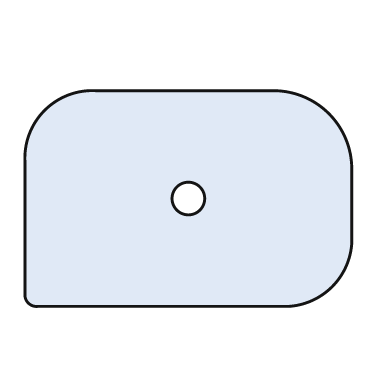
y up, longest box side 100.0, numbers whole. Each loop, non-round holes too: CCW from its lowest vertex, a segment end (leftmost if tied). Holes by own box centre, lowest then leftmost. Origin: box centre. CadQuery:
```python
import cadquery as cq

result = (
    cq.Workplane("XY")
    .moveTo(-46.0, -33.0)
    .lineTo(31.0, -33.0)
    .threePointArc((44.0, -27.0), (50.0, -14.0))
    .lineTo(50.0, 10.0)
    .threePointArc((43.0, 26.0), (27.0, 33.0))
    .lineTo(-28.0, 33.0)
    .threePointArc((-44.0, 27.0), (-50.0, 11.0))
    .lineTo(-50.0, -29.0)
    .threePointArc((-49.0, -32.0), (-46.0, -33.0))
    .close()
    .moveTo(0.0, 0.0)
    .circle(5.0)
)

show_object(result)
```